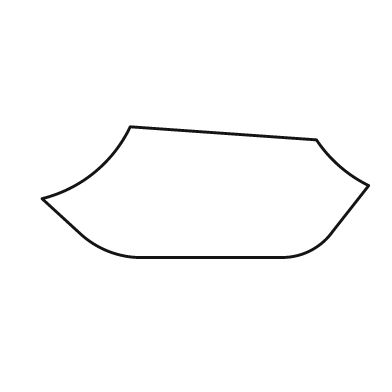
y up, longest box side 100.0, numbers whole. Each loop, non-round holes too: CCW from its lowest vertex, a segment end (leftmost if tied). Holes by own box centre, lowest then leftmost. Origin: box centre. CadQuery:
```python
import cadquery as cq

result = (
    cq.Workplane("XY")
    .moveTo(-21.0, -20.0)
    .lineTo(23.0, -20.0)
    .threePointArc((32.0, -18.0), (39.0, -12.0))
    .lineTo(50.0, 2.0)
    .threePointArc((41.0, 8.0), (34.0, 16.0))
    .lineTo(-23.0, 20.0)
    .threePointArc((-34.0, 6.0), (-50.0, -2.0))
    .lineTo(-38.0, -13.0)
    .threePointArc((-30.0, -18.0), (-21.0, -20.0))
    .close()
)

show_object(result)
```